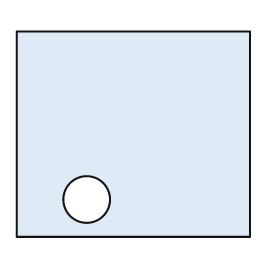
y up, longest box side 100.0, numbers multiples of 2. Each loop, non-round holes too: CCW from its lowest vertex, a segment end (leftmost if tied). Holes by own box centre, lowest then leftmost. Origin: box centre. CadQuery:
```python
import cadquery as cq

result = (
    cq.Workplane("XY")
    .moveTo(-50.0, -44.0)
    .lineTo(50.0, -44.0)
    .lineTo(50.0, 44.0)
    .lineTo(-50.0, 44.0)
    .close()
    .moveTo(-20.0, -28.0)
    .circle(10.0)
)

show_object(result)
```